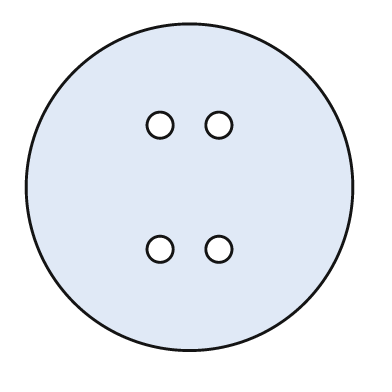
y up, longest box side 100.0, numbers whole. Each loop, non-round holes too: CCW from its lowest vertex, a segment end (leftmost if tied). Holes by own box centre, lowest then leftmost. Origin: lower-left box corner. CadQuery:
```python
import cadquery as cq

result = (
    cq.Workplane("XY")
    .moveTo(50.0, 50.0)
    .circle(50.0)
    .moveTo(41.0, 31.0)
    .circle(4.0)
    .moveTo(59.0, 31.0)
    .circle(4.0)
    .moveTo(41.0, 69.0)
    .circle(4.0)
    .moveTo(59.0, 69.0)
    .circle(4.0)
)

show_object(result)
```